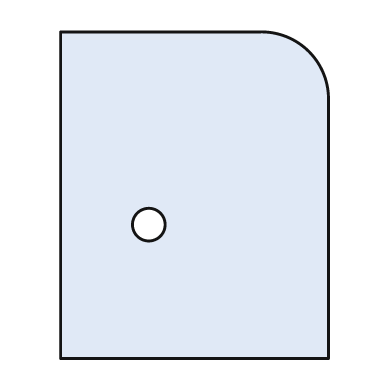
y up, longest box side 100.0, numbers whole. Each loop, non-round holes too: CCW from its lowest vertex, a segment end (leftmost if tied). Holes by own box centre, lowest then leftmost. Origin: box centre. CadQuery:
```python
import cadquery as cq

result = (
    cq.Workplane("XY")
    .moveTo(-41.0, -50.0)
    .lineTo(41.0, -50.0)
    .lineTo(41.0, 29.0)
    .threePointArc((35.0, 44.0), (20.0, 50.0))
    .lineTo(-41.0, 50.0)
    .close()
    .moveTo(-14.0, -9.0)
    .circle(5.0)
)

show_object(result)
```